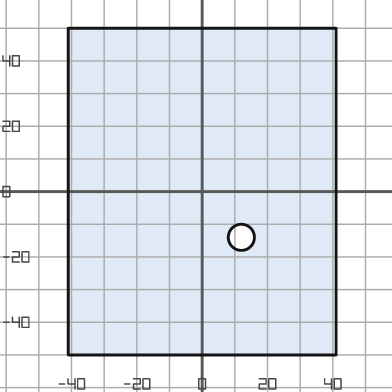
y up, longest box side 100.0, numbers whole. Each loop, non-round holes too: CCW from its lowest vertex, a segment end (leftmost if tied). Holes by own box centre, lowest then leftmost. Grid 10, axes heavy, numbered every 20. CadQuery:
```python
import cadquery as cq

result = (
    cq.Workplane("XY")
    .moveTo(-41.0, -50.0)
    .lineTo(41.0, -50.0)
    .lineTo(41.0, 50.0)
    .lineTo(-41.0, 50.0)
    .close()
    .moveTo(12.0, -14.0)
    .circle(4.0)
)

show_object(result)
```